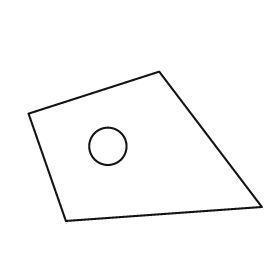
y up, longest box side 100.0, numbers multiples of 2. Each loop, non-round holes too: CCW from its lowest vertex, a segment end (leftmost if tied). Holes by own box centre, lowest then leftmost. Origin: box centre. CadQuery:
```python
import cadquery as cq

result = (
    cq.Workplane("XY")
    .moveTo(-34.0, -32.0)
    .lineTo(50.0, -26.0)
    .lineTo(6.0, 32.0)
    .lineTo(-50.0, 14.0)
    .close()
    .moveTo(-16.0, 0.0)
    .circle(8.0)
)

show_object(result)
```